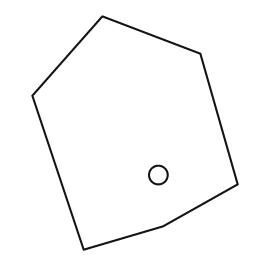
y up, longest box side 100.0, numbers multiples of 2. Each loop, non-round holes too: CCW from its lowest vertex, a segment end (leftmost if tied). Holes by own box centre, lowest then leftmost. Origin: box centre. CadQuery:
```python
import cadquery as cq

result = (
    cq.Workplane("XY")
    .moveTo(-22.0, -50.0)
    .lineTo(12.0, -40.0)
    .lineTo(44.0, -22.0)
    .lineTo(28.0, 34.0)
    .lineTo(-14.0, 50.0)
    .lineTo(-44.0, 16.0)
    .close()
    .moveTo(10.0, -18.0)
    .circle(4.0)
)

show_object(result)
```